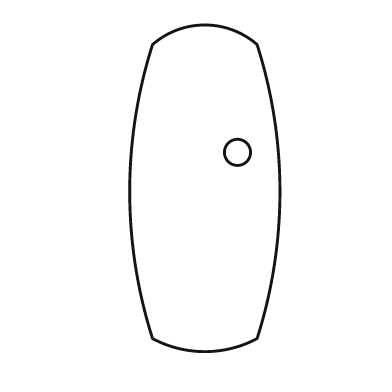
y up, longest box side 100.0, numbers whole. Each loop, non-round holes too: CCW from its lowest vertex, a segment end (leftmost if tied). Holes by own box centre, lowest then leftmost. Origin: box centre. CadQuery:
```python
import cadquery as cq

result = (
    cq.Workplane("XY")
    .moveTo(-16.0, -46.0)
    .threePointArc((0.0, -50.0), (16.0, -46.0))
    .threePointArc((23.0, -1.0), (16.0, 44.0))
    .threePointArc((0.0, 50.0), (-16.0, 44.0))
    .threePointArc((-23.0, -1.0), (-16.0, -46.0))
    .close()
    .moveTo(10.0, 11.0)
    .circle(4.0)
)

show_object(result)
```